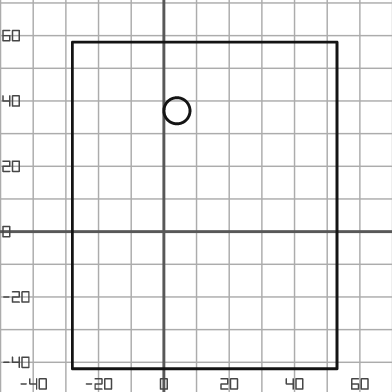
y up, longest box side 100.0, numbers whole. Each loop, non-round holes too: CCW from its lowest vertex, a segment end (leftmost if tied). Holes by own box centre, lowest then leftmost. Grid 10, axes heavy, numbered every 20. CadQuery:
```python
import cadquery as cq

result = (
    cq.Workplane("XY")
    .moveTo(-28.0, -42.0)
    .lineTo(53.0, -42.0)
    .lineTo(53.0, 58.0)
    .lineTo(-28.0, 58.0)
    .close()
    .moveTo(4.0, 37.0)
    .circle(4.0)
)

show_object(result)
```